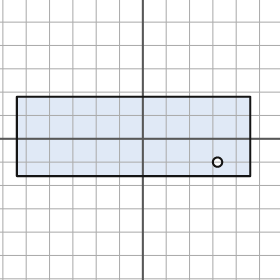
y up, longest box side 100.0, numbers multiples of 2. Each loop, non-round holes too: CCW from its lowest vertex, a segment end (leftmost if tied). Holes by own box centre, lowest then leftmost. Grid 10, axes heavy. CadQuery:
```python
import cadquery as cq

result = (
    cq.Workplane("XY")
    .moveTo(-54.0, -16.0)
    .lineTo(46.0, -16.0)
    .lineTo(46.0, 18.0)
    .lineTo(-54.0, 18.0)
    .close()
    .moveTo(32.0, -10.0)
    .circle(2.0)
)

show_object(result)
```